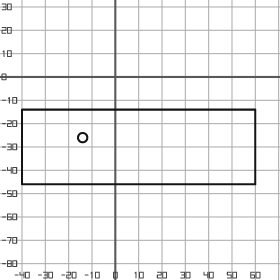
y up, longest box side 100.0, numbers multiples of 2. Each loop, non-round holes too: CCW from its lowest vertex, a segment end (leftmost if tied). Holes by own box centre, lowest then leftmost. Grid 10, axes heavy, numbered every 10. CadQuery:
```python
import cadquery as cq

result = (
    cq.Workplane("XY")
    .moveTo(-40.0, -46.0)
    .lineTo(60.0, -46.0)
    .lineTo(60.0, -14.0)
    .lineTo(-40.0, -14.0)
    .close()
    .moveTo(-14.0, -26.0)
    .circle(2.0)
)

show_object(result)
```